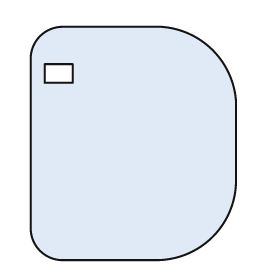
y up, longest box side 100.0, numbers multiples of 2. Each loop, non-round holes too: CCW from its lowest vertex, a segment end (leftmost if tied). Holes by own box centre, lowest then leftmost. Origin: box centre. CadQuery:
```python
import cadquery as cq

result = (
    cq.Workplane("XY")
    .moveTo(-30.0, -50.0)
    .lineTo(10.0, -50.0)
    .threePointArc((34.0, -40.0), (44.0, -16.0))
    .lineTo(44.0, 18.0)
    .threePointArc((34.0, 40.0), (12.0, 50.0))
    .lineTo(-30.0, 50.0)
    .threePointArc((-40.0, 46.0), (-44.0, 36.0))
    .lineTo(-44.0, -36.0)
    .threePointArc((-40.0, -46.0), (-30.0, -50.0))
    .close()
    .moveTo(-38.0, 26.0)
    .lineTo(-26.0, 26.0)
    .lineTo(-26.0, 34.0)
    .lineTo(-38.0, 34.0)
    .close()
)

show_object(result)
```